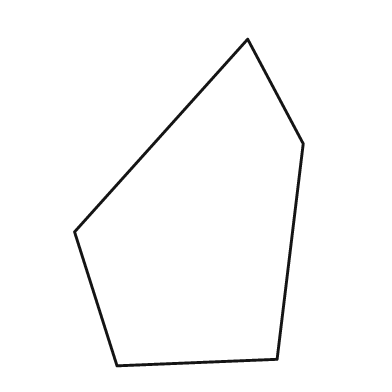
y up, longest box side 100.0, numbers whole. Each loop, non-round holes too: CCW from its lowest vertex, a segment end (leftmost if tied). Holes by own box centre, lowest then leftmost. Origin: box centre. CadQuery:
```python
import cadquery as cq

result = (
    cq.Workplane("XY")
    .moveTo(-22.0, -50.0)
    .lineTo(27.0, -48.0)
    .lineTo(35.0, 18.0)
    .lineTo(18.0, 50.0)
    .lineTo(-35.0, -9.0)
    .close()
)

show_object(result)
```